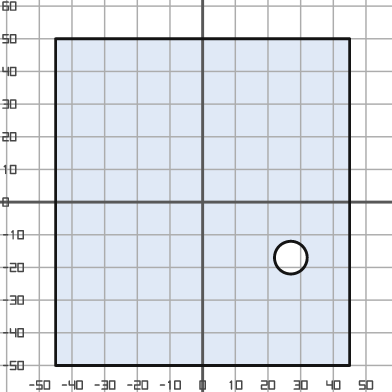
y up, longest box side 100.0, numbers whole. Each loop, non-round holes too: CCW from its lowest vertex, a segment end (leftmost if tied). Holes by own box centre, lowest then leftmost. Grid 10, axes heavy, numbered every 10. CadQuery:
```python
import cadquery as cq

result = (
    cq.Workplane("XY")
    .moveTo(-45.0, -50.0)
    .lineTo(45.0, -50.0)
    .lineTo(45.0, 50.0)
    .lineTo(-45.0, 50.0)
    .close()
    .moveTo(27.0, -17.0)
    .circle(5.0)
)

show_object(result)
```